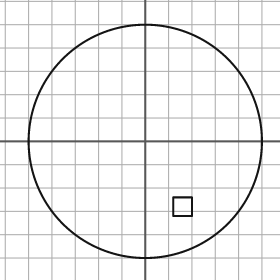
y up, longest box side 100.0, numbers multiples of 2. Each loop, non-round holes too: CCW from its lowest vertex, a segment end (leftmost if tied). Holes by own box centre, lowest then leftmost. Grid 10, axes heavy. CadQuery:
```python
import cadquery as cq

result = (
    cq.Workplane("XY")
    .moveTo(0.0, 0.0)
    .circle(50.0)
    .moveTo(12.0, -32.0)
    .lineTo(20.0, -32.0)
    .lineTo(20.0, -24.0)
    .lineTo(12.0, -24.0)
    .close()
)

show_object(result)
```